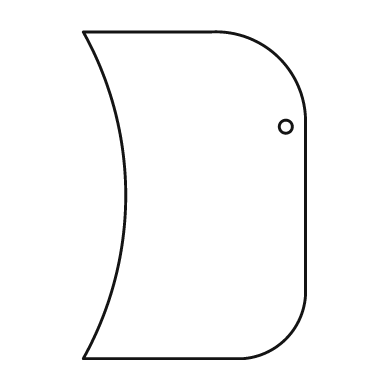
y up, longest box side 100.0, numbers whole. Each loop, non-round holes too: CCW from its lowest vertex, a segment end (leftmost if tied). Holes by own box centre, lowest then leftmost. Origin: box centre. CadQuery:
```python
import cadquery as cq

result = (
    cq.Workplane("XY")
    .moveTo(-34.0, -50.0)
    .lineTo(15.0, -50.0)
    .threePointArc((28.0, -44.0), (34.0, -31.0))
    .lineTo(34.0, 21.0)
    .threePointArc((26.0, 42.0), (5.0, 50.0))
    .lineTo(-34.0, 50.0)
    .threePointArc((-21.0, 0.0), (-34.0, -50.0))
    .close()
    .moveTo(28.0, 21.0)
    .circle(2.0)
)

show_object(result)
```